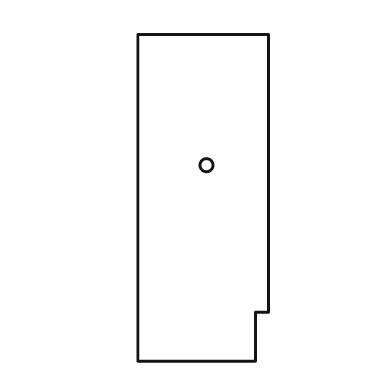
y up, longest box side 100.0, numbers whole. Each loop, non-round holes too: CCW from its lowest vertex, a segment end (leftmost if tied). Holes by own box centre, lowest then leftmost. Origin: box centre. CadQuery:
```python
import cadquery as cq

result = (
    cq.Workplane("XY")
    .moveTo(-20.0, -50.0)
    .lineTo(16.0, -50.0)
    .lineTo(16.0, -35.0)
    .lineTo(20.0, -35.0)
    .lineTo(20.0, 50.0)
    .lineTo(-20.0, 50.0)
    .close()
    .moveTo(1.0, 10.0)
    .circle(2.0)
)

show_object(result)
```